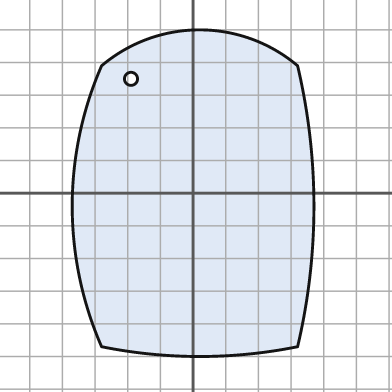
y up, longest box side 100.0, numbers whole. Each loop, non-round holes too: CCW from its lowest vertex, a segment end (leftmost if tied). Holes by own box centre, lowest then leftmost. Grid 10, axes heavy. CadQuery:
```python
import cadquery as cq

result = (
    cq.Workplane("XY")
    .moveTo(-28.0, -47.0)
    .threePointArc((2.0, -50.0), (32.0, -47.0))
    .threePointArc((37.0, -4.0), (32.0, 39.0))
    .threePointArc((2.0, 50.0), (-28.0, 39.0))
    .threePointArc((-37.0, -4.0), (-28.0, -47.0))
    .close()
    .moveTo(-19.0, 35.0)
    .circle(2.0)
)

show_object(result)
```